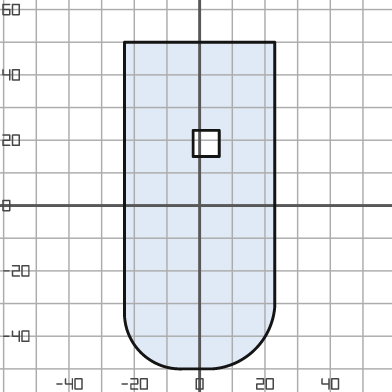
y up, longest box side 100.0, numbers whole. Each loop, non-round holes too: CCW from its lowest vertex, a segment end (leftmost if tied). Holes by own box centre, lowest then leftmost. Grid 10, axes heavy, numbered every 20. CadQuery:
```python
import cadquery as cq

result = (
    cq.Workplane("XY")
    .moveTo(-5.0, -50.0)
    .lineTo(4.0, -50.0)
    .threePointArc((17.0, -44.0), (23.0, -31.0))
    .lineTo(23.0, 50.0)
    .lineTo(-23.0, 50.0)
    .lineTo(-23.0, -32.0)
    .threePointArc((-18.0, -45.0), (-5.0, -50.0))
    .close()
    .moveTo(-2.0, 15.0)
    .lineTo(6.0, 15.0)
    .lineTo(6.0, 23.0)
    .lineTo(-2.0, 23.0)
    .close()
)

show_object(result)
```